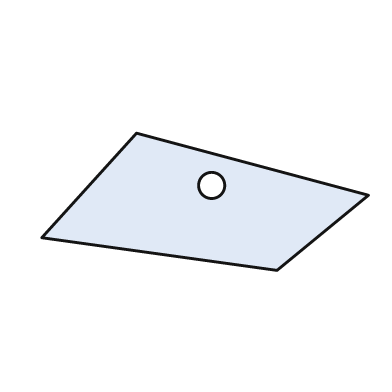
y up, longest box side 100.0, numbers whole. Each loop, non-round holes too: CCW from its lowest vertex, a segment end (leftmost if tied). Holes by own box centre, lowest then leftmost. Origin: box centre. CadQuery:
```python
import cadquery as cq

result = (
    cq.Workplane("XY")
    .moveTo(22.0, -21.0)
    .lineTo(50.0, 2.0)
    .lineTo(-21.0, 21.0)
    .lineTo(-50.0, -11.0)
    .close()
    .moveTo(2.0, 5.0)
    .circle(4.0)
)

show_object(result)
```